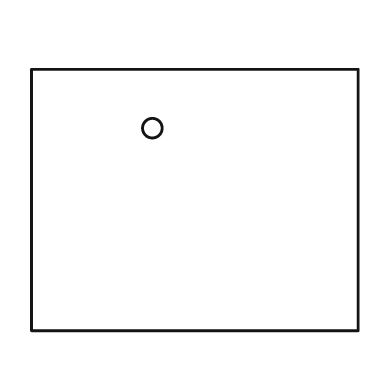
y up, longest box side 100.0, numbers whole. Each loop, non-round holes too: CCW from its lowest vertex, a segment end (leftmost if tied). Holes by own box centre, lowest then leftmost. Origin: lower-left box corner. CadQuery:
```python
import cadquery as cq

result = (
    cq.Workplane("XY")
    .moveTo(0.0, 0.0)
    .lineTo(100.0, 0.0)
    .lineTo(100.0, 80.0)
    .lineTo(0.0, 80.0)
    .close()
    .moveTo(37.0, 62.0)
    .circle(3.0)
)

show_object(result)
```